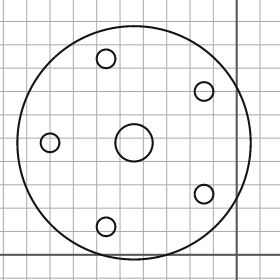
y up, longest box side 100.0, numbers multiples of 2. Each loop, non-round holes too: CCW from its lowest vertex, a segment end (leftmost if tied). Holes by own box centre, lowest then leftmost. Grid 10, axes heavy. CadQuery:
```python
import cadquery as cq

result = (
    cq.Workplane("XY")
    .moveTo(-44.0, 48.0)
    .circle(50.0)
    .moveTo(-56.0, 12.0)
    .circle(4.0)
    .moveTo(-14.0, 26.0)
    .circle(4.0)
    .moveTo(-80.0, 48.0)
    .circle(4.0)
    .moveTo(-44.0, 48.0)
    .circle(8.0)
    .moveTo(-14.0, 70.0)
    .circle(4.0)
    .moveTo(-56.0, 84.0)
    .circle(4.0)
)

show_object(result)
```